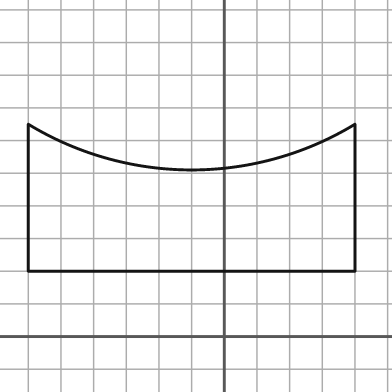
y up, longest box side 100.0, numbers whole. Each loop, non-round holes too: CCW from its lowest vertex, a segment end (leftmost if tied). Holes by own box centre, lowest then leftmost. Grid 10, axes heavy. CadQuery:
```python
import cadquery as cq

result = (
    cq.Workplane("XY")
    .moveTo(-60.0, 20.0)
    .lineTo(40.0, 20.0)
    .lineTo(40.0, 65.0)
    .threePointArc((-10.0, 51.0), (-60.0, 65.0))
    .close()
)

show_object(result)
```